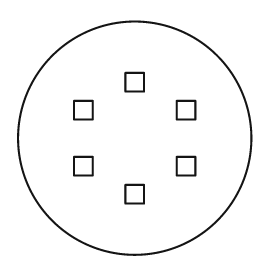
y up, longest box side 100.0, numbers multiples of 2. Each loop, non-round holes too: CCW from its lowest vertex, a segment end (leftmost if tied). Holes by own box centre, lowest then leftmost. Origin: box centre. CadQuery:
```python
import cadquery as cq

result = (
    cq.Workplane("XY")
    .moveTo(0.0, 0.0)
    .circle(50.0)
    .moveTo(-4.0, -28.0)
    .lineTo(4.0, -28.0)
    .lineTo(4.0, -20.0)
    .lineTo(-4.0, -20.0)
    .close()
    .moveTo(-26.0, -16.0)
    .lineTo(-18.0, -16.0)
    .lineTo(-18.0, -8.0)
    .lineTo(-26.0, -8.0)
    .close()
    .moveTo(18.0, -16.0)
    .lineTo(26.0, -16.0)
    .lineTo(26.0, -8.0)
    .lineTo(18.0, -8.0)
    .close()
    .moveTo(-26.0, 8.0)
    .lineTo(-18.0, 8.0)
    .lineTo(-18.0, 16.0)
    .lineTo(-26.0, 16.0)
    .close()
    .moveTo(18.0, 8.0)
    .lineTo(26.0, 8.0)
    .lineTo(26.0, 16.0)
    .lineTo(18.0, 16.0)
    .close()
    .moveTo(-4.0, 20.0)
    .lineTo(4.0, 20.0)
    .lineTo(4.0, 28.0)
    .lineTo(-4.0, 28.0)
    .close()
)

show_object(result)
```